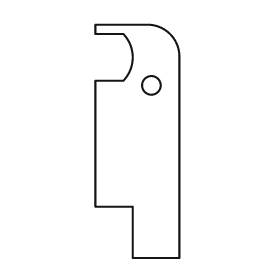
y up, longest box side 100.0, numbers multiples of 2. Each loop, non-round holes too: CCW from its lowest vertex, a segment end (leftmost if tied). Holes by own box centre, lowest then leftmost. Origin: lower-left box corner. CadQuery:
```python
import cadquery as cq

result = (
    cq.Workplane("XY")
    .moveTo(16.0, 0.0)
    .lineTo(36.0, 0.0)
    .lineTo(36.0, 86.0)
    .threePointArc((32.0, 96.0), (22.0, 100.0))
    .lineTo(0.0, 100.0)
    .lineTo(0.0, 96.0)
    .lineTo(12.0, 96.0)
    .threePointArc((16.0, 86.0), (12.0, 76.0))
    .lineTo(0.0, 76.0)
    .lineTo(0.0, 22.0)
    .lineTo(16.0, 22.0)
    .close()
    .moveTo(24.0, 74.0)
    .circle(4.0)
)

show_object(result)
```